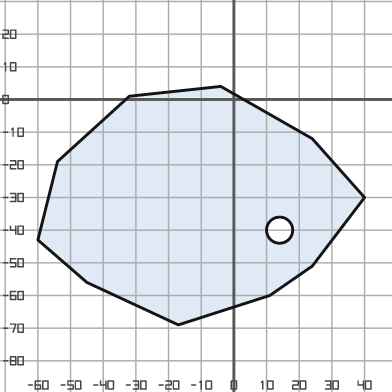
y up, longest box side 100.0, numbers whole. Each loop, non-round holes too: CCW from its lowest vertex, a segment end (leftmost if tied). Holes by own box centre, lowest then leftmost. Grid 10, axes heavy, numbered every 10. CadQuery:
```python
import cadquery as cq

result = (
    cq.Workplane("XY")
    .moveTo(-17.0, -69.0)
    .lineTo(11.0, -60.0)
    .lineTo(24.0, -51.0)
    .lineTo(40.0, -30.0)
    .lineTo(24.0, -12.0)
    .lineTo(-4.0, 4.0)
    .lineTo(-32.0, 1.0)
    .lineTo(-54.0, -19.0)
    .lineTo(-60.0, -43.0)
    .lineTo(-45.0, -56.0)
    .close()
    .moveTo(14.0, -40.0)
    .circle(4.0)
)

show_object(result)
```